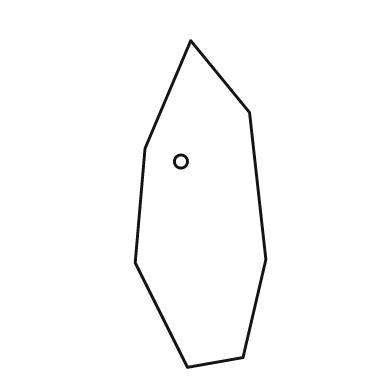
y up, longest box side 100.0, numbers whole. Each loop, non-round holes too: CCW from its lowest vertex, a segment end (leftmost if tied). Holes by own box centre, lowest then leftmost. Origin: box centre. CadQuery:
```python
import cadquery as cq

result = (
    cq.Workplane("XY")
    .moveTo(-4.0, -50.0)
    .lineTo(13.0, -47.0)
    .lineTo(20.0, -17.0)
    .lineTo(15.0, 28.0)
    .lineTo(-3.0, 50.0)
    .lineTo(-17.0, 17.0)
    .lineTo(-20.0, -18.0)
    .close()
    .moveTo(-6.0, 13.0)
    .circle(2.0)
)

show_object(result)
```